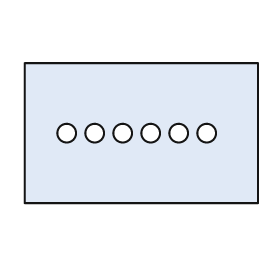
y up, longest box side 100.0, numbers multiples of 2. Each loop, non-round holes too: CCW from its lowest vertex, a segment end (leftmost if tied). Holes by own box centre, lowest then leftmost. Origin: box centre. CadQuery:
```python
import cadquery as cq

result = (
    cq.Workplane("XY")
    .moveTo(-50.0, -30.0)
    .lineTo(50.0, -30.0)
    .lineTo(50.0, 30.0)
    .lineTo(-50.0, 30.0)
    .close()
    .moveTo(-32.0, 0.0)
    .circle(4.0)
    .moveTo(-20.0, 0.0)
    .circle(4.0)
    .moveTo(-8.0, 0.0)
    .circle(4.0)
    .moveTo(4.0, 0.0)
    .circle(4.0)
    .moveTo(16.0, 0.0)
    .circle(4.0)
    .moveTo(28.0, 0.0)
    .circle(4.0)
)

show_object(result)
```